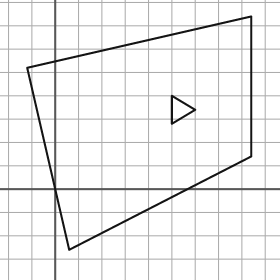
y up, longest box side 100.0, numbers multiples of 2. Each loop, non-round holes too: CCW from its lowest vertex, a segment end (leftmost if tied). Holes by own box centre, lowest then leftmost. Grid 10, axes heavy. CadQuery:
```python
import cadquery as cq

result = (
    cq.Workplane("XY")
    .moveTo(6.0, -26.0)
    .lineTo(84.0, 14.0)
    .lineTo(84.0, 74.0)
    .lineTo(-12.0, 52.0)
    .close()
    .moveTo(50.0, 28.0)
    .lineTo(60.0, 34.0)
    .lineTo(50.0, 40.0)
    .close()
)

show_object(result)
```